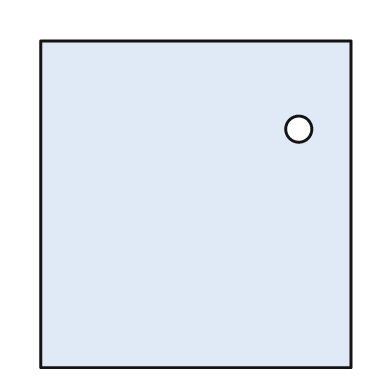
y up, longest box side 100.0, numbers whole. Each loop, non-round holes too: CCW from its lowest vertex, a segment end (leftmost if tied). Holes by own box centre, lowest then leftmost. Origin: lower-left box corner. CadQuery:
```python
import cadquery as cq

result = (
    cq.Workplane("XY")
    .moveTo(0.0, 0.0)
    .lineTo(95.0, 0.0)
    .lineTo(95.0, 100.0)
    .lineTo(0.0, 100.0)
    .close()
    .moveTo(79.0, 73.0)
    .circle(4.0)
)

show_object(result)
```